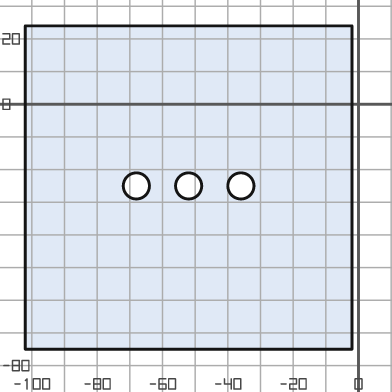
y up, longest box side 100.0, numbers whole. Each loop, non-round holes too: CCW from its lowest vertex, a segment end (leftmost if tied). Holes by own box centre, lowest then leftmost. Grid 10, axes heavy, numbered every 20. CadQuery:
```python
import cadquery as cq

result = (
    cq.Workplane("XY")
    .moveTo(-102.0, -75.0)
    .lineTo(-2.0, -75.0)
    .lineTo(-2.0, 24.0)
    .lineTo(-102.0, 24.0)
    .close()
    .moveTo(-68.0, -25.0)
    .circle(4.0)
    .moveTo(-52.0, -25.0)
    .circle(4.0)
    .moveTo(-36.0, -25.0)
    .circle(4.0)
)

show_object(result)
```